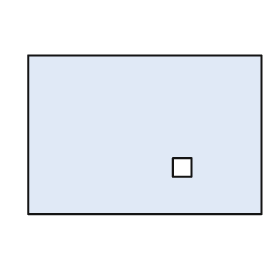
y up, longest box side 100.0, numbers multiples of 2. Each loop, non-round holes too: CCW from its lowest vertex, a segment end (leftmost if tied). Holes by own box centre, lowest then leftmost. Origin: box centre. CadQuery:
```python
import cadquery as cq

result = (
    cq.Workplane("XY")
    .moveTo(-50.0, -34.0)
    .lineTo(50.0, -34.0)
    .lineTo(50.0, 34.0)
    .lineTo(-50.0, 34.0)
    .close()
    .moveTo(12.0, -18.0)
    .lineTo(20.0, -18.0)
    .lineTo(20.0, -10.0)
    .lineTo(12.0, -10.0)
    .close()
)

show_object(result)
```